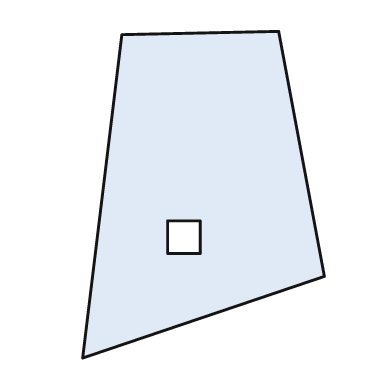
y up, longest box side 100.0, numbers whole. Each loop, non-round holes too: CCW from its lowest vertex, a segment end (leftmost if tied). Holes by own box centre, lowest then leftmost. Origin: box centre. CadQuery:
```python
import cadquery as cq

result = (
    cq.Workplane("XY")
    .moveTo(-37.0, -50.0)
    .lineTo(37.0, -25.0)
    .lineTo(23.0, 50.0)
    .lineTo(-25.0, 49.0)
    .close()
    .moveTo(-11.0, -18.0)
    .lineTo(-1.0, -18.0)
    .lineTo(-1.0, -8.0)
    .lineTo(-11.0, -8.0)
    .close()
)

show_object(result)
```